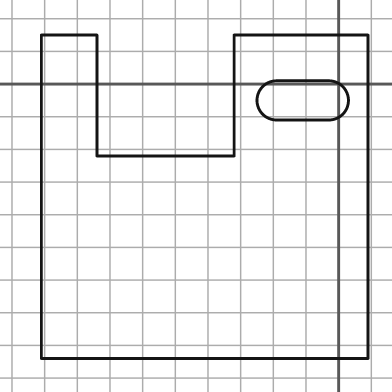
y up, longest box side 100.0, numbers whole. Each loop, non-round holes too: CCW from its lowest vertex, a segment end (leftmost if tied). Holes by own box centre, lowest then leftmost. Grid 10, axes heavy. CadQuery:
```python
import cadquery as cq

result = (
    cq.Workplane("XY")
    .moveTo(-91.0, -84.0)
    .lineTo(9.0, -84.0)
    .lineTo(9.0, 15.0)
    .lineTo(-32.0, 15.0)
    .lineTo(-32.0, -22.0)
    .lineTo(-74.0, -22.0)
    .lineTo(-74.0, 15.0)
    .lineTo(-91.0, 15.0)
    .close()
    .moveTo(-19.0, -11.0)
    .lineTo(-3.0, -11.0)
    .threePointArc((3.0, -5.0), (-3.0, 1.0))
    .lineTo(-19.0, 1.0)
    .threePointArc((-25.0, -5.0), (-19.0, -11.0))
    .close()
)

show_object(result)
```